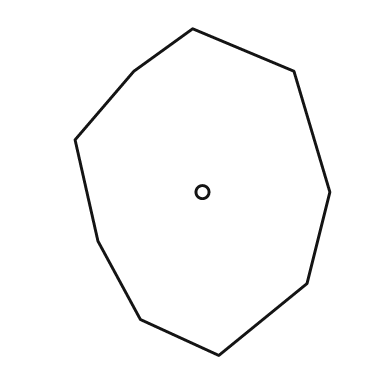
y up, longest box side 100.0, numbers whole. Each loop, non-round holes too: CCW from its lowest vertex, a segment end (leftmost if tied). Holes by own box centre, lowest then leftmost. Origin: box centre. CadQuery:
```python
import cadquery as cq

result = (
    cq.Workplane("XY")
    .moveTo(5.0, -50.0)
    .lineTo(32.0, -28.0)
    .lineTo(39.0, 0.0)
    .lineTo(28.0, 37.0)
    .lineTo(-3.0, 50.0)
    .lineTo(-21.0, 37.0)
    .lineTo(-39.0, 16.0)
    .lineTo(-32.0, -15.0)
    .lineTo(-19.0, -39.0)
    .close()
    .moveTo(0.0, 0.0)
    .circle(2.0)
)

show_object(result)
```